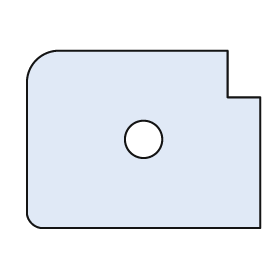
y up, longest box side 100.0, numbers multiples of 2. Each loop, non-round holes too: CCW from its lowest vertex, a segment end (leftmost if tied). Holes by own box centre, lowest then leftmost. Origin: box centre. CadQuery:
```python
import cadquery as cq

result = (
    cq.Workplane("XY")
    .moveTo(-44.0, -38.0)
    .lineTo(50.0, -38.0)
    .lineTo(50.0, 18.0)
    .lineTo(36.0, 18.0)
    .lineTo(36.0, 38.0)
    .lineTo(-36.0, 38.0)
    .threePointArc((-46.0, 34.0), (-50.0, 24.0))
    .lineTo(-50.0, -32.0)
    .threePointArc((-48.0, -36.0), (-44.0, -38.0))
    .close()
    .moveTo(0.0, 0.0)
    .circle(8.0)
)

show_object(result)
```